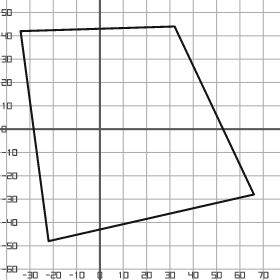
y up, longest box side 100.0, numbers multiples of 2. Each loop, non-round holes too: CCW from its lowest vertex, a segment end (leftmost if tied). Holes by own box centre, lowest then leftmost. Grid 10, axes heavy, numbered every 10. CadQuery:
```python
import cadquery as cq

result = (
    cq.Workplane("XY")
    .moveTo(-22.0, -48.0)
    .lineTo(66.0, -28.0)
    .lineTo(32.0, 44.0)
    .lineTo(-34.0, 42.0)
    .close()
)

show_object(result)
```